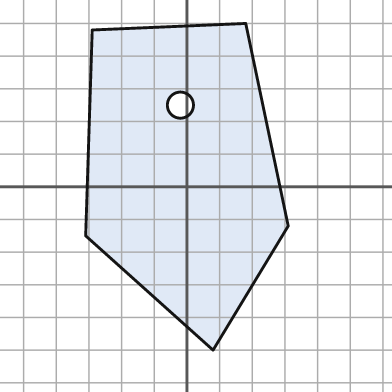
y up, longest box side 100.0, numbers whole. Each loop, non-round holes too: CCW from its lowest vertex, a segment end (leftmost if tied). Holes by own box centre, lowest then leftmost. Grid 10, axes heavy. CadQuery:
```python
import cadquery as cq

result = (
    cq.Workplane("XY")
    .moveTo(8.0, -50.0)
    .lineTo(31.0, -12.0)
    .lineTo(18.0, 50.0)
    .lineTo(-29.0, 48.0)
    .lineTo(-31.0, -15.0)
    .close()
    .moveTo(-2.0, 25.0)
    .circle(4.0)
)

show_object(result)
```